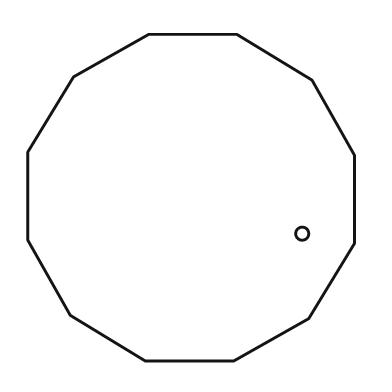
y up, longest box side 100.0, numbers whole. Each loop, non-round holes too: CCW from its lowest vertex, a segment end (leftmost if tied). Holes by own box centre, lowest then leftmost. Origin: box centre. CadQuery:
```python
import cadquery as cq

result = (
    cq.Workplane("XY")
    .moveTo(-14.0, -50.0)
    .lineTo(13.0, -50.0)
    .lineTo(36.0, -37.0)
    .lineTo(50.0, -14.0)
    .lineTo(50.0, 13.0)
    .lineTo(37.0, 36.0)
    .lineTo(14.0, 50.0)
    .lineTo(-13.0, 50.0)
    .lineTo(-36.0, 37.0)
    .lineTo(-50.0, 14.0)
    .lineTo(-50.0, -13.0)
    .lineTo(-37.0, -36.0)
    .close()
    .moveTo(34.0, -11.0)
    .circle(2.0)
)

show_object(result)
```